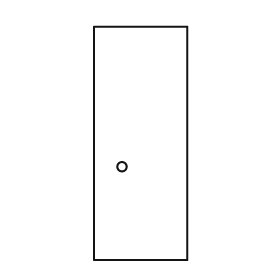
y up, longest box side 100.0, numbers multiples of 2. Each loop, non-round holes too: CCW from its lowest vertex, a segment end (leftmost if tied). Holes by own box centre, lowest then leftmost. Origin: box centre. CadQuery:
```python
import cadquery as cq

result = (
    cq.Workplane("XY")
    .moveTo(-20.0, -50.0)
    .lineTo(20.0, -50.0)
    .lineTo(20.0, 50.0)
    .lineTo(-20.0, 50.0)
    .close()
    .moveTo(-8.0, -10.0)
    .circle(2.0)
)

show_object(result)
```